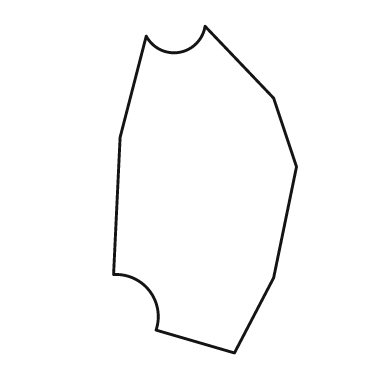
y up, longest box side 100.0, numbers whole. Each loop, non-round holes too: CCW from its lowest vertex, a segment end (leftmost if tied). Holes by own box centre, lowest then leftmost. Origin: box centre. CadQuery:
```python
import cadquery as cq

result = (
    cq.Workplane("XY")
    .moveTo(9.0, -50.0)
    .lineTo(21.0, -27.0)
    .lineTo(28.0, 7.0)
    .lineTo(21.0, 28.0)
    .lineTo(0.0, 50.0)
    .threePointArc((-8.0, 42.0), (-18.0, 47.0))
    .lineTo(-26.0, 16.0)
    .lineTo(-28.0, -26.0)
    .threePointArc((-17.0, -31.0), (-15.0, -43.0))
    .close()
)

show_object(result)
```